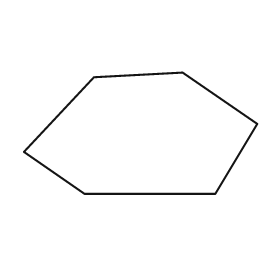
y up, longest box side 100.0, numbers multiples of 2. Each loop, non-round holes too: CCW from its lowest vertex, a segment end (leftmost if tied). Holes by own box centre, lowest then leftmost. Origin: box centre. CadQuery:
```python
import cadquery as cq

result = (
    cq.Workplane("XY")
    .moveTo(-24.0, -26.0)
    .lineTo(32.0, -26.0)
    .lineTo(50.0, 4.0)
    .lineTo(18.0, 26.0)
    .lineTo(-20.0, 24.0)
    .lineTo(-50.0, -8.0)
    .close()
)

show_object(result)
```